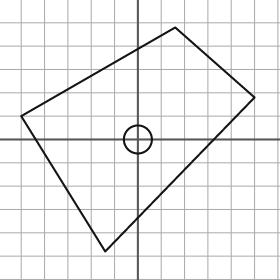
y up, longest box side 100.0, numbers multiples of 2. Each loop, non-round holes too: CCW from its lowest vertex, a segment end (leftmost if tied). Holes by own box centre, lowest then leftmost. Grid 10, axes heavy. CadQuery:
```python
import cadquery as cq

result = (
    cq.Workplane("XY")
    .moveTo(-14.0, -48.0)
    .lineTo(50.0, 18.0)
    .lineTo(16.0, 48.0)
    .lineTo(-50.0, 10.0)
    .close()
    .moveTo(0.0, 0.0)
    .circle(6.0)
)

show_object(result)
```